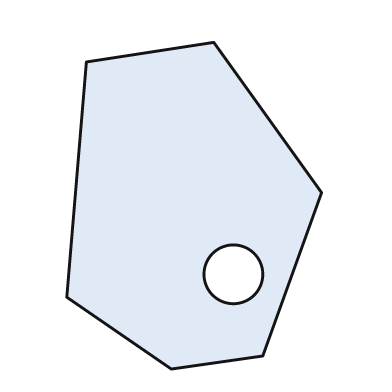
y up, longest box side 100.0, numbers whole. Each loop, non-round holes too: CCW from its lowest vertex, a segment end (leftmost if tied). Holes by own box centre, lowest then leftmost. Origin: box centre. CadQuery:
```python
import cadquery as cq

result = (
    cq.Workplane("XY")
    .moveTo(-7.0, -50.0)
    .lineTo(21.0, -46.0)
    .lineTo(39.0, 4.0)
    .lineTo(6.0, 50.0)
    .lineTo(-33.0, 44.0)
    .lineTo(-39.0, -28.0)
    .close()
    .moveTo(12.0, -21.0)
    .circle(9.0)
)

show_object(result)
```